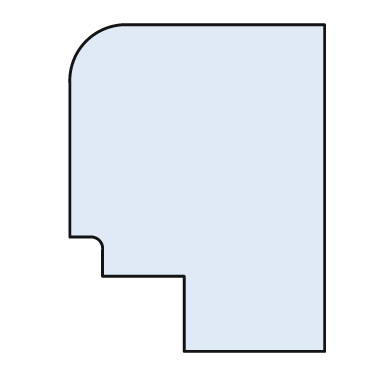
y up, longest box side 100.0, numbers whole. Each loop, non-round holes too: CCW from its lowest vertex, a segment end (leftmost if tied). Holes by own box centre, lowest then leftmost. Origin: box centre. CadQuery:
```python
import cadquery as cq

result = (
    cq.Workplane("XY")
    .moveTo(-4.0, -50.0)
    .lineTo(39.0, -50.0)
    .lineTo(39.0, 50.0)
    .lineTo(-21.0, 50.0)
    .threePointArc((-34.0, 45.0), (-39.0, 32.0))
    .lineTo(-39.0, -15.0)
    .lineTo(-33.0, -15.0)
    .threePointArc((-30.0, -16.0), (-29.0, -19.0))
    .lineTo(-29.0, -27.0)
    .lineTo(-4.0, -27.0)
    .close()
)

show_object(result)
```